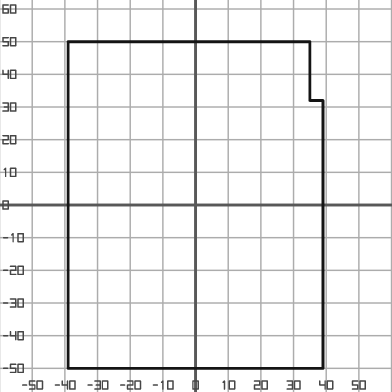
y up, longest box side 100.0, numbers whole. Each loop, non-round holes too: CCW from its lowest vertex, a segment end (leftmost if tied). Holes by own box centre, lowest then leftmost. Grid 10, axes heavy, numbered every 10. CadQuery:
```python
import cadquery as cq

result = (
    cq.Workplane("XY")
    .moveTo(-39.0, -50.0)
    .lineTo(39.0, -50.0)
    .lineTo(39.0, 32.0)
    .lineTo(35.0, 32.0)
    .lineTo(35.0, 50.0)
    .lineTo(-39.0, 50.0)
    .close()
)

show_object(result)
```